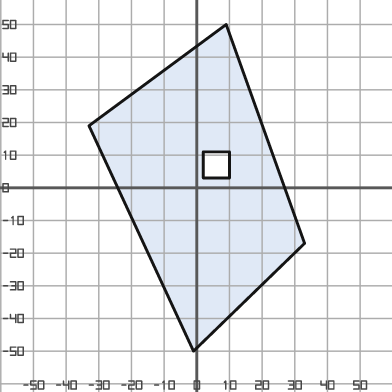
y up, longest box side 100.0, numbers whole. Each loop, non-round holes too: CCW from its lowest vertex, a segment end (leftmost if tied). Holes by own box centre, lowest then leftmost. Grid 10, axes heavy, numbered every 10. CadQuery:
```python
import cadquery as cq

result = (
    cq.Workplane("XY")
    .moveTo(-1.0, -50.0)
    .lineTo(33.0, -17.0)
    .lineTo(9.0, 50.0)
    .lineTo(-33.0, 19.0)
    .close()
    .moveTo(2.0, 3.0)
    .lineTo(10.0, 3.0)
    .lineTo(10.0, 11.0)
    .lineTo(2.0, 11.0)
    .close()
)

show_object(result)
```